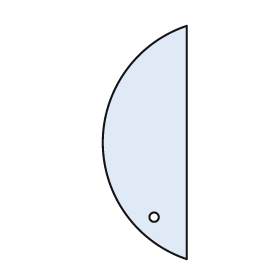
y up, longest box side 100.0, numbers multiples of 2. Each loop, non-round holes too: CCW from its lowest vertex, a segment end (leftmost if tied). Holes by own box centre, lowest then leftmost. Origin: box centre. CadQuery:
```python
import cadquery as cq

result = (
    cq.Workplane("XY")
    .moveTo(18.0, -50.0)
    .lineTo(18.0, 50.0)
    .threePointArc((-18.0, 0.0), (18.0, -50.0))
    .close()
    .moveTo(4.0, -32.0)
    .circle(2.0)
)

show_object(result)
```